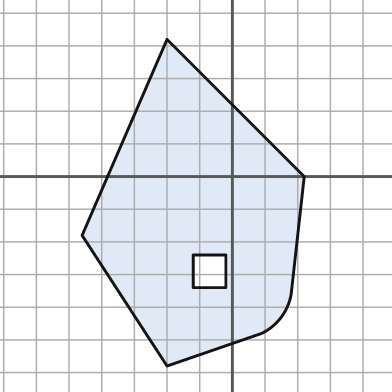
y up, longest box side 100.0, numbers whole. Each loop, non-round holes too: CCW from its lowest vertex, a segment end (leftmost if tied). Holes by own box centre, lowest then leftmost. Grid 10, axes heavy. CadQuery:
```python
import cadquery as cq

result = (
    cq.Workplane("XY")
    .moveTo(-20.0, -58.0)
    .lineTo(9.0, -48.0)
    .threePointArc((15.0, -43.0), (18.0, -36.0))
    .lineTo(22.0, 0.0)
    .lineTo(-20.0, 42.0)
    .lineTo(-46.0, -18.0)
    .close()
    .moveTo(-12.0, -34.0)
    .lineTo(-2.0, -34.0)
    .lineTo(-2.0, -24.0)
    .lineTo(-12.0, -24.0)
    .close()
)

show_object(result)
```